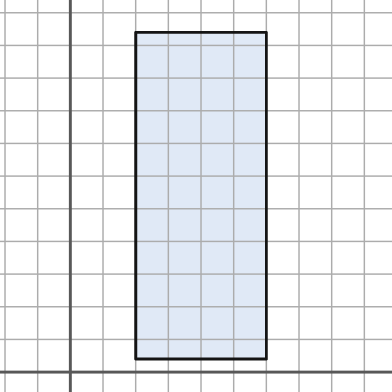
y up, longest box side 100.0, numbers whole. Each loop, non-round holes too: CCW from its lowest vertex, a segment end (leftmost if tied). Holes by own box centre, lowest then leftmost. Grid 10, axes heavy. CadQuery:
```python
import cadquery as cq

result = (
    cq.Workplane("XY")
    .moveTo(20.0, 4.0)
    .lineTo(60.0, 4.0)
    .lineTo(60.0, 104.0)
    .lineTo(20.0, 104.0)
    .close()
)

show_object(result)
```